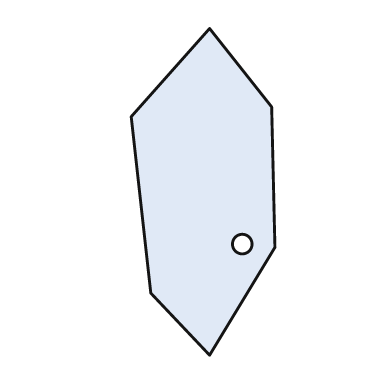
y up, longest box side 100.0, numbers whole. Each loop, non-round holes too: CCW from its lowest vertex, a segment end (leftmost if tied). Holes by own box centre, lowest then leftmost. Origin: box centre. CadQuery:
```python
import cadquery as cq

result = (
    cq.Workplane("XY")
    .moveTo(2.0, -50.0)
    .lineTo(22.0, -17.0)
    .lineTo(21.0, 26.0)
    .lineTo(2.0, 50.0)
    .lineTo(-22.0, 23.0)
    .lineTo(-16.0, -31.0)
    .close()
    .moveTo(12.0, -16.0)
    .circle(3.0)
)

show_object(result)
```